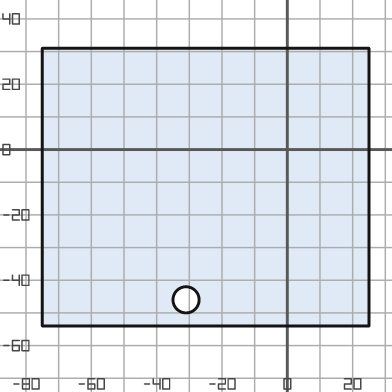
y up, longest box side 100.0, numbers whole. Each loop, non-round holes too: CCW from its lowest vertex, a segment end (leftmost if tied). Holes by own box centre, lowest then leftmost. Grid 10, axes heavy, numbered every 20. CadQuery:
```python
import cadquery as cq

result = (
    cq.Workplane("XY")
    .moveTo(-75.0, -54.0)
    .lineTo(25.0, -54.0)
    .lineTo(25.0, 31.0)
    .lineTo(-75.0, 31.0)
    .close()
    .moveTo(-31.0, -46.0)
    .circle(4.0)
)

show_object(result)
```